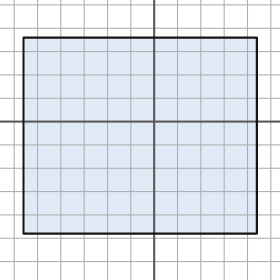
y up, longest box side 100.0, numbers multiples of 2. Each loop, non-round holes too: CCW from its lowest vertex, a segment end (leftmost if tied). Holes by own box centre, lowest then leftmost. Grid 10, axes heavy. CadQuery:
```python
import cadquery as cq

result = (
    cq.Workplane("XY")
    .moveTo(-56.0, -48.0)
    .lineTo(44.0, -48.0)
    .lineTo(44.0, 36.0)
    .lineTo(-56.0, 36.0)
    .close()
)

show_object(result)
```